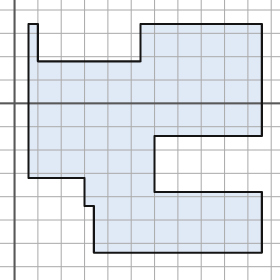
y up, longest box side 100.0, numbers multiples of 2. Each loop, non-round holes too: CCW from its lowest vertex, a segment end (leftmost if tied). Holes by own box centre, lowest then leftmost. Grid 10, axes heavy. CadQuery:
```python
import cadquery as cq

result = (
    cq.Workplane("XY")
    .moveTo(34.0, -64.0)
    .lineTo(106.0, -64.0)
    .lineTo(106.0, -38.0)
    .lineTo(60.0, -38.0)
    .lineTo(60.0, -14.0)
    .lineTo(106.0, -14.0)
    .lineTo(106.0, 34.0)
    .lineTo(54.0, 34.0)
    .lineTo(54.0, 18.0)
    .lineTo(10.0, 18.0)
    .lineTo(10.0, 34.0)
    .lineTo(6.0, 34.0)
    .lineTo(6.0, -32.0)
    .lineTo(30.0, -32.0)
    .lineTo(30.0, -44.0)
    .lineTo(34.0, -44.0)
    .close()
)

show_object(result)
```